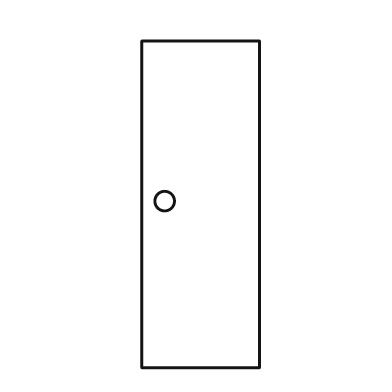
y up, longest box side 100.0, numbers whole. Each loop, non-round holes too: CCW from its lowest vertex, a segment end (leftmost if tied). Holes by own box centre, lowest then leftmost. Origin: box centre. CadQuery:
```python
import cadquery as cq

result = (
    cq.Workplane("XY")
    .moveTo(-18.0, -50.0)
    .lineTo(18.0, -50.0)
    .lineTo(18.0, 50.0)
    .lineTo(-18.0, 50.0)
    .close()
    .moveTo(-11.0, 1.0)
    .circle(3.0)
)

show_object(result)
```